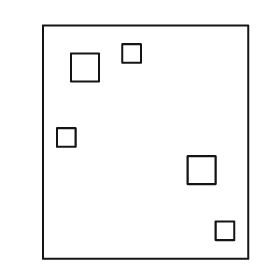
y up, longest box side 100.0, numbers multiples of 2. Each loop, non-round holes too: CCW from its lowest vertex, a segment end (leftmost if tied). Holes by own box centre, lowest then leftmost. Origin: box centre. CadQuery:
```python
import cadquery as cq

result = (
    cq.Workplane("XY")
    .moveTo(-44.0, -50.0)
    .lineTo(44.0, -50.0)
    .lineTo(44.0, 50.0)
    .lineTo(-44.0, 50.0)
    .close()
    .moveTo(30.0, -42.0)
    .lineTo(38.0, -42.0)
    .lineTo(38.0, -34.0)
    .lineTo(30.0, -34.0)
    .close()
    .moveTo(18.0, -18.0)
    .lineTo(30.0, -18.0)
    .lineTo(30.0, -6.0)
    .lineTo(18.0, -6.0)
    .close()
    .moveTo(-38.0, -2.0)
    .lineTo(-30.0, -2.0)
    .lineTo(-30.0, 6.0)
    .lineTo(-38.0, 6.0)
    .close()
    .moveTo(-32.0, 26.0)
    .lineTo(-20.0, 26.0)
    .lineTo(-20.0, 38.0)
    .lineTo(-32.0, 38.0)
    .close()
    .moveTo(-10.0, 34.0)
    .lineTo(-2.0, 34.0)
    .lineTo(-2.0, 42.0)
    .lineTo(-10.0, 42.0)
    .close()
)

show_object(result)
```